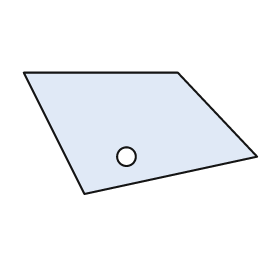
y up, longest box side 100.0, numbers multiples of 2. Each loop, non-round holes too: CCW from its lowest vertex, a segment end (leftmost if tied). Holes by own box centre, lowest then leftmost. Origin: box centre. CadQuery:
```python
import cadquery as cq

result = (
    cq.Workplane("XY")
    .moveTo(-24.0, -26.0)
    .lineTo(50.0, -10.0)
    .lineTo(16.0, 26.0)
    .lineTo(-50.0, 26.0)
    .close()
    .moveTo(-6.0, -10.0)
    .circle(4.0)
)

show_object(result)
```